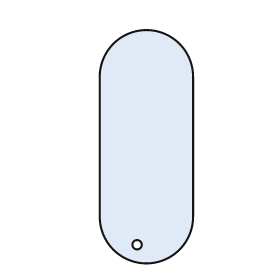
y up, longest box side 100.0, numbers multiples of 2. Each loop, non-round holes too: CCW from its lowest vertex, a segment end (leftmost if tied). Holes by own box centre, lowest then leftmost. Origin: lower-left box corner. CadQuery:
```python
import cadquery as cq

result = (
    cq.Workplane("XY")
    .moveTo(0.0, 20.0)
    .threePointArc((20.0, 0.0), (40.0, 20.0))
    .lineTo(40.0, 80.0)
    .threePointArc((20.0, 100.0), (0.0, 80.0))
    .close()
    .moveTo(16.0, 8.0)
    .circle(2.0)
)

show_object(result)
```